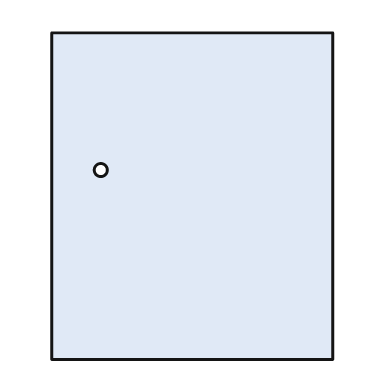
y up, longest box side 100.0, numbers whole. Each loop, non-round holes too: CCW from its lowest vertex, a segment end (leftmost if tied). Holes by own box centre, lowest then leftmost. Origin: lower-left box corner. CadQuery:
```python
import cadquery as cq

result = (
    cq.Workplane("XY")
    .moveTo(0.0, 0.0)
    .lineTo(86.0, 0.0)
    .lineTo(86.0, 100.0)
    .lineTo(0.0, 100.0)
    .close()
    .moveTo(15.0, 58.0)
    .circle(2.0)
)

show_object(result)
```